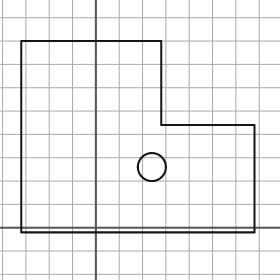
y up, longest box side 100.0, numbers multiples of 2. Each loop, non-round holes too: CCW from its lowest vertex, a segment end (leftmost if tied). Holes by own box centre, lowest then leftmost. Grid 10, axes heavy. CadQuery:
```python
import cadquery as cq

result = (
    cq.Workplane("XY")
    .moveTo(-32.0, -2.0)
    .lineTo(68.0, -2.0)
    .lineTo(68.0, 44.0)
    .lineTo(28.0, 44.0)
    .lineTo(28.0, 80.0)
    .lineTo(-32.0, 80.0)
    .close()
    .moveTo(24.0, 26.0)
    .circle(6.0)
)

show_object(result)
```